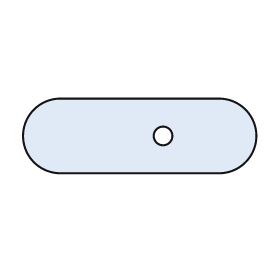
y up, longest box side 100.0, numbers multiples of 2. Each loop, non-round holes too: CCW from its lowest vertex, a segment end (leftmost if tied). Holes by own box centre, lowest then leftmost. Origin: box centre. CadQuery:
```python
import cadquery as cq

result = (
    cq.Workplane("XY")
    .moveTo(-34.0, -16.0)
    .lineTo(34.0, -16.0)
    .threePointArc((50.0, 0.0), (34.0, 16.0))
    .lineTo(-34.0, 16.0)
    .threePointArc((-50.0, 0.0), (-34.0, -16.0))
    .close()
    .moveTo(10.0, 0.0)
    .circle(4.0)
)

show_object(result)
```